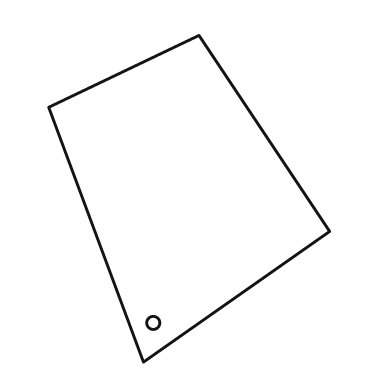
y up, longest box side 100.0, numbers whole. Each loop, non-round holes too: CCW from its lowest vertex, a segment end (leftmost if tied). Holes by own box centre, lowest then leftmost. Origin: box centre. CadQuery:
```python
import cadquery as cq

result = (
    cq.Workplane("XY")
    .moveTo(-14.0, -50.0)
    .lineTo(43.0, -10.0)
    .lineTo(3.0, 50.0)
    .lineTo(-43.0, 28.0)
    .close()
    .moveTo(-11.0, -38.0)
    .circle(2.0)
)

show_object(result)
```